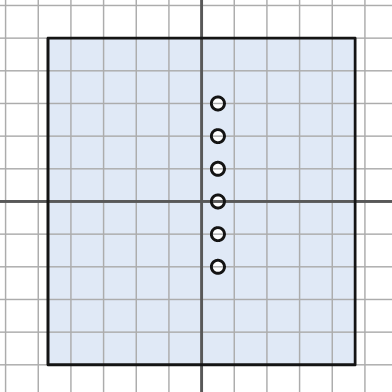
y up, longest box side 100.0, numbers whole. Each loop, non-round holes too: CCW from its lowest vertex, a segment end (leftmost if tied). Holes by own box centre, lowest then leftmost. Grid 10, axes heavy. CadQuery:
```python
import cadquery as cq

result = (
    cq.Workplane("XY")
    .moveTo(-47.0, -50.0)
    .lineTo(47.0, -50.0)
    .lineTo(47.0, 50.0)
    .lineTo(-47.0, 50.0)
    .close()
    .moveTo(5.0, -20.0)
    .circle(2.0)
    .moveTo(5.0, -10.0)
    .circle(2.0)
    .moveTo(5.0, 0.0)
    .circle(2.0)
    .moveTo(5.0, 10.0)
    .circle(2.0)
    .moveTo(5.0, 20.0)
    .circle(2.0)
    .moveTo(5.0, 30.0)
    .circle(2.0)
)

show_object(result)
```